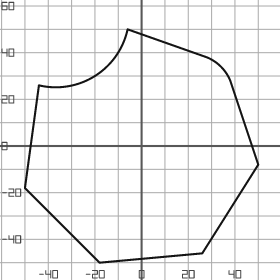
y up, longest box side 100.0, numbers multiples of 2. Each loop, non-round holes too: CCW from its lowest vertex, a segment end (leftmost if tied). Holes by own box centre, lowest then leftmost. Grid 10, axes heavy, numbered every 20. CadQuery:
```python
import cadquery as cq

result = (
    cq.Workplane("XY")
    .moveTo(-18.0, -50.0)
    .lineTo(26.0, -46.0)
    .lineTo(50.0, -8.0)
    .lineTo(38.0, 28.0)
    .threePointArc((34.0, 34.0), (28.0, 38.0))
    .lineTo(-6.0, 50.0)
    .threePointArc((-20.0, 30.0), (-44.0, 26.0))
    .lineTo(-50.0, -18.0)
    .close()
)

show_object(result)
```